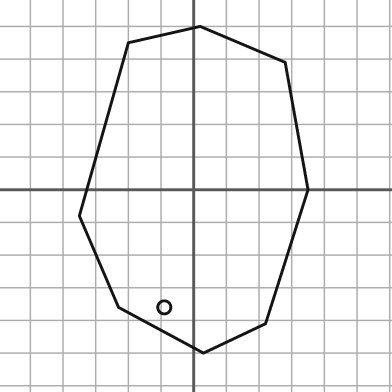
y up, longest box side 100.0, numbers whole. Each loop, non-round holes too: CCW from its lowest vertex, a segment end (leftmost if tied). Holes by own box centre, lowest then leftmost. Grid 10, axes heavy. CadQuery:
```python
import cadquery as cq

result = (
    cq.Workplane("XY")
    .moveTo(3.0, -50.0)
    .lineTo(22.0, -41.0)
    .lineTo(35.0, 0.0)
    .lineTo(28.0, 39.0)
    .lineTo(2.0, 50.0)
    .lineTo(-20.0, 45.0)
    .lineTo(-35.0, -8.0)
    .lineTo(-23.0, -36.0)
    .close()
    .moveTo(-9.0, -36.0)
    .circle(2.0)
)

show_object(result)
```